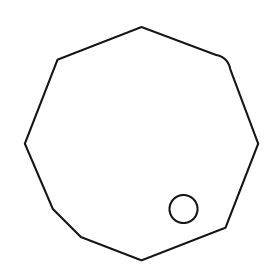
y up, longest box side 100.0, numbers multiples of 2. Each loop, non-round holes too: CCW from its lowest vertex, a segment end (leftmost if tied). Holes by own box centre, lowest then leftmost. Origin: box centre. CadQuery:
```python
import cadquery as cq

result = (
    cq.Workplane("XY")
    .moveTo(0.0, -50.0)
    .lineTo(36.0, -36.0)
    .lineTo(50.0, 0.0)
    .lineTo(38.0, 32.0)
    .threePointArc((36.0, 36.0), (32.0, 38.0))
    .lineTo(0.0, 50.0)
    .lineTo(-36.0, 36.0)
    .lineTo(-50.0, 0.0)
    .lineTo(-38.0, -28.0)
    .lineTo(-26.0, -40.0)
    .close()
    .moveTo(18.0, -28.0)
    .circle(6.0)
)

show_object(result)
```